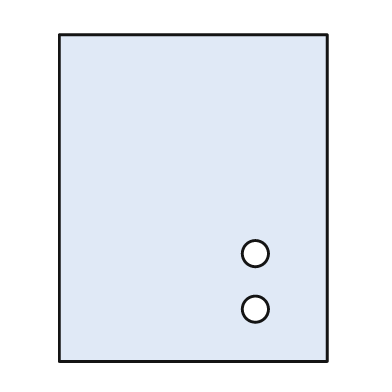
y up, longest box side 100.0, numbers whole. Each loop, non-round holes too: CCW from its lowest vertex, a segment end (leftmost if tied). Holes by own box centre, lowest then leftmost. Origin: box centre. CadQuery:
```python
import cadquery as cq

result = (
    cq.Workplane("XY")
    .moveTo(-41.0, -50.0)
    .lineTo(41.0, -50.0)
    .lineTo(41.0, 50.0)
    .lineTo(-41.0, 50.0)
    .close()
    .moveTo(19.0, -34.0)
    .circle(4.0)
    .moveTo(19.0, -17.0)
    .circle(4.0)
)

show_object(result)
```